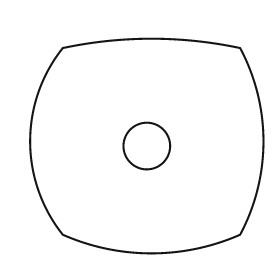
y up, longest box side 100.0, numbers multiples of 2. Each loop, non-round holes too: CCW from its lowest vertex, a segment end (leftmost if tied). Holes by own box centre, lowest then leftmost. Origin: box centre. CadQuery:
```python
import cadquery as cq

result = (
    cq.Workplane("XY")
    .moveTo(-36.0, -38.0)
    .threePointArc((2.0, -46.0), (40.0, -38.0))
    .threePointArc((50.0, 2.0), (40.0, 42.0))
    .threePointArc((2.0, 46.0), (-36.0, 42.0))
    .threePointArc((-50.0, 2.0), (-36.0, -38.0))
    .close()
    .moveTo(0.0, 0.0)
    .circle(10.0)
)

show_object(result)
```